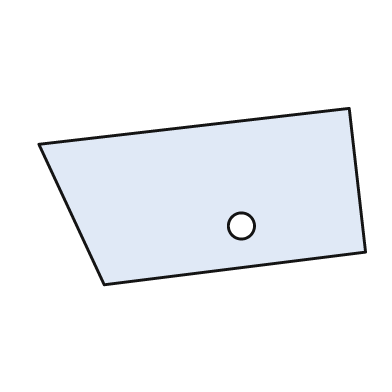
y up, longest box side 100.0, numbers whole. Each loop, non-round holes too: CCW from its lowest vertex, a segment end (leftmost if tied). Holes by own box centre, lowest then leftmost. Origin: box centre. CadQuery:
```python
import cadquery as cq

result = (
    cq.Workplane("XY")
    .moveTo(-30.0, -27.0)
    .lineTo(50.0, -17.0)
    .lineTo(45.0, 27.0)
    .lineTo(-50.0, 16.0)
    .close()
    .moveTo(12.0, -9.0)
    .circle(4.0)
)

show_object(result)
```